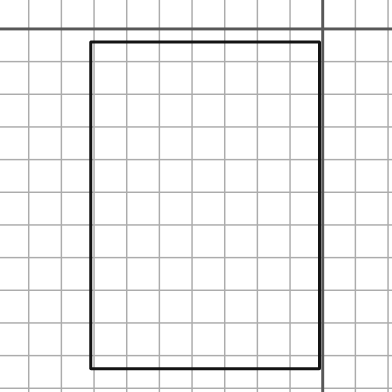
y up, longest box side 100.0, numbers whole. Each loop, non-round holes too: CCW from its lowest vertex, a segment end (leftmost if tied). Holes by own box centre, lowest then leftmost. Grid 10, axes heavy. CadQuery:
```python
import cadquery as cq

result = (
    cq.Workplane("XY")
    .moveTo(-71.0, -104.0)
    .lineTo(-1.0, -104.0)
    .lineTo(-1.0, -4.0)
    .lineTo(-71.0, -4.0)
    .close()
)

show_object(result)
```